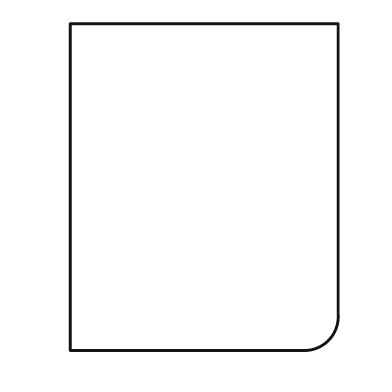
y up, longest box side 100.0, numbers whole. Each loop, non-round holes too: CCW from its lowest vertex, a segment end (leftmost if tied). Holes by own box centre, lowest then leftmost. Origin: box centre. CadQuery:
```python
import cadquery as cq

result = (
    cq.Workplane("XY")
    .moveTo(-41.0, -50.0)
    .lineTo(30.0, -50.0)
    .threePointArc((38.0, -47.0), (41.0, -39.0))
    .lineTo(41.0, 50.0)
    .lineTo(-41.0, 50.0)
    .close()
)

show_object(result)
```